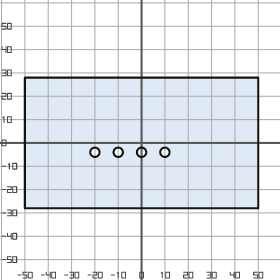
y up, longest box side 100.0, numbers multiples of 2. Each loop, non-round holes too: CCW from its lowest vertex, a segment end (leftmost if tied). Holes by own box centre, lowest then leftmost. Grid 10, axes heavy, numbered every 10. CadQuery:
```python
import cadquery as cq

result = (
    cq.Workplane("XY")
    .moveTo(-50.0, -28.0)
    .lineTo(50.0, -28.0)
    .lineTo(50.0, 28.0)
    .lineTo(-50.0, 28.0)
    .close()
    .moveTo(-20.0, -4.0)
    .circle(2.0)
    .moveTo(-10.0, -4.0)
    .circle(2.0)
    .moveTo(0.0, -4.0)
    .circle(2.0)
    .moveTo(10.0, -4.0)
    .circle(2.0)
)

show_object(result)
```